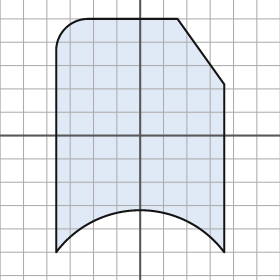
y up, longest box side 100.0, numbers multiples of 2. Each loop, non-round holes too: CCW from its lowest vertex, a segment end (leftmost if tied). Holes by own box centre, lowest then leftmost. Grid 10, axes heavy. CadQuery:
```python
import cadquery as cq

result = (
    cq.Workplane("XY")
    .moveTo(-36.0, -50.0)
    .threePointArc((0.0, -32.0), (36.0, -50.0))
    .lineTo(36.0, 22.0)
    .lineTo(16.0, 50.0)
    .lineTo(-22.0, 50.0)
    .threePointArc((-32.0, 46.0), (-36.0, 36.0))
    .close()
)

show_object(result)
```